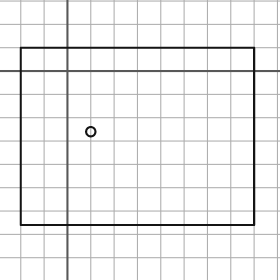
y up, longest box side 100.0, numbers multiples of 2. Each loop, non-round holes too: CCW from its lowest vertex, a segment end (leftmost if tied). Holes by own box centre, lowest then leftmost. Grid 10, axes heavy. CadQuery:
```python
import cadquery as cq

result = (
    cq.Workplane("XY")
    .moveTo(-20.0, -66.0)
    .lineTo(80.0, -66.0)
    .lineTo(80.0, 10.0)
    .lineTo(-20.0, 10.0)
    .close()
    .moveTo(10.0, -26.0)
    .circle(2.0)
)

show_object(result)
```